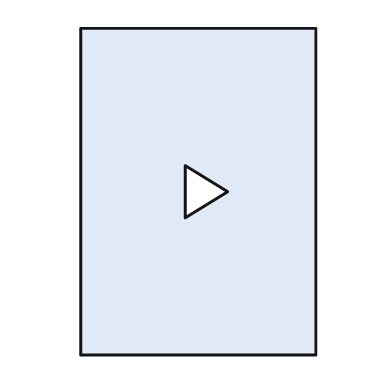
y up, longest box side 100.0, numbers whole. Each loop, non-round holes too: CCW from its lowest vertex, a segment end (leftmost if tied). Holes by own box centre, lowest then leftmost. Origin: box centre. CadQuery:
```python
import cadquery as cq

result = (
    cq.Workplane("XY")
    .moveTo(-36.0, -50.0)
    .lineTo(36.0, -50.0)
    .lineTo(36.0, 50.0)
    .lineTo(-36.0, 50.0)
    .close()
    .moveTo(-4.0, -8.0)
    .lineTo(9.0, 0.0)
    .lineTo(-4.0, 8.0)
    .close()
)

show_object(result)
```